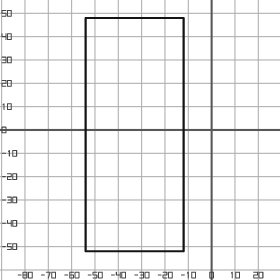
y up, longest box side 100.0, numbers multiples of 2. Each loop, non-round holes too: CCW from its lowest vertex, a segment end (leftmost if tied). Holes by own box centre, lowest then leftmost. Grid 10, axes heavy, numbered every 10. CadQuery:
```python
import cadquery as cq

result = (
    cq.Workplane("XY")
    .moveTo(-54.0, -52.0)
    .lineTo(-12.0, -52.0)
    .lineTo(-12.0, 48.0)
    .lineTo(-54.0, 48.0)
    .close()
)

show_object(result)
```